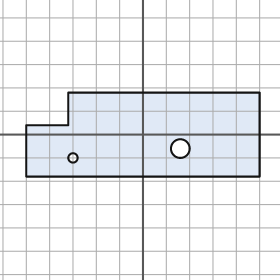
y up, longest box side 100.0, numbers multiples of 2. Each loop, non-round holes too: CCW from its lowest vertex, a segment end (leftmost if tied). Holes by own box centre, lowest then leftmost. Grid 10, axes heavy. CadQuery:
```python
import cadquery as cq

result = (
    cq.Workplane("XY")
    .moveTo(-50.0, -18.0)
    .lineTo(50.0, -18.0)
    .lineTo(50.0, 18.0)
    .lineTo(-32.0, 18.0)
    .lineTo(-32.0, 4.0)
    .lineTo(-50.0, 4.0)
    .close()
    .moveTo(-30.0, -10.0)
    .circle(2.0)
    .moveTo(16.0, -6.0)
    .circle(4.0)
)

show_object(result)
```